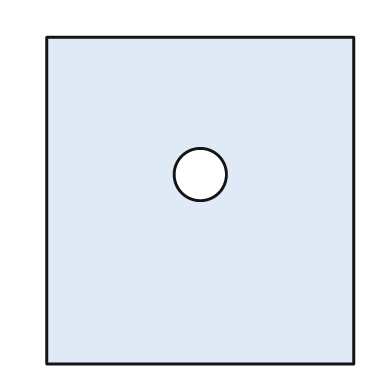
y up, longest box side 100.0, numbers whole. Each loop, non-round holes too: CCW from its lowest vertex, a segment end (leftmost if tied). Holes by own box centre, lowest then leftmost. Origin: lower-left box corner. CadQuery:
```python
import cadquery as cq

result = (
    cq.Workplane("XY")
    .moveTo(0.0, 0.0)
    .lineTo(94.0, 0.0)
    .lineTo(94.0, 100.0)
    .lineTo(0.0, 100.0)
    .close()
    .moveTo(47.0, 58.0)
    .circle(8.0)
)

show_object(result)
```